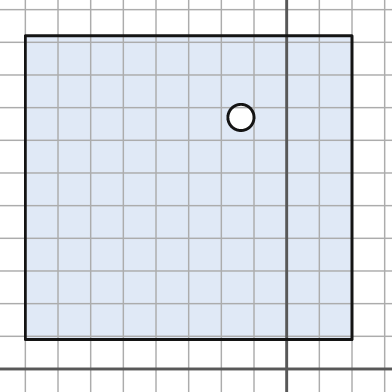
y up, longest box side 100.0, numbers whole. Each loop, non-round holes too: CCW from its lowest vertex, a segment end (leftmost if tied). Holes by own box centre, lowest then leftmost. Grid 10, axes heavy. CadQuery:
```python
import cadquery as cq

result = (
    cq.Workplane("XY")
    .moveTo(-80.0, 9.0)
    .lineTo(20.0, 9.0)
    .lineTo(20.0, 102.0)
    .lineTo(-80.0, 102.0)
    .close()
    .moveTo(-14.0, 77.0)
    .circle(4.0)
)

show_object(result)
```